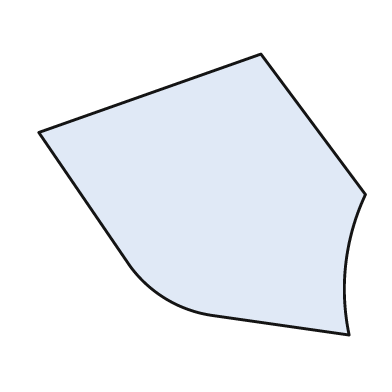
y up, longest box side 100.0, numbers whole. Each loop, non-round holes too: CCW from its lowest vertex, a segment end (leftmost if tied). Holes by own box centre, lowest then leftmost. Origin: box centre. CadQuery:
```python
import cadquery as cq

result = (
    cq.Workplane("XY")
    .moveTo(45.0, -43.0)
    .threePointArc((44.0, -21.0), (50.0, 0.0))
    .lineTo(18.0, 43.0)
    .lineTo(-50.0, 19.0)
    .lineTo(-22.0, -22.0)
    .threePointArc((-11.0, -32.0), (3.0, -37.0))
    .close()
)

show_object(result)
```